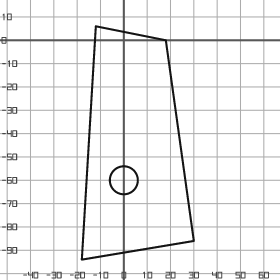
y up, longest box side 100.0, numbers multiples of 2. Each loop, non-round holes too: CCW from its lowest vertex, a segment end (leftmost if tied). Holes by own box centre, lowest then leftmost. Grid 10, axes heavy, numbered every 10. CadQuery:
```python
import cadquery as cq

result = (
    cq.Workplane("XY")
    .moveTo(-18.0, -94.0)
    .lineTo(30.0, -86.0)
    .lineTo(18.0, 0.0)
    .lineTo(-12.0, 6.0)
    .close()
    .moveTo(0.0, -60.0)
    .circle(6.0)
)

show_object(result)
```